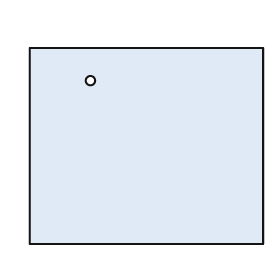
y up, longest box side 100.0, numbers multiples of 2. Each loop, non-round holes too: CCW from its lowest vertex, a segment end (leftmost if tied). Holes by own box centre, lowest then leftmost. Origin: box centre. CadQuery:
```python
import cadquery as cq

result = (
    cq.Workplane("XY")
    .moveTo(-50.0, -42.0)
    .lineTo(50.0, -42.0)
    .lineTo(50.0, 42.0)
    .lineTo(-50.0, 42.0)
    .close()
    .moveTo(-24.0, 28.0)
    .circle(2.0)
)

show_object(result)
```